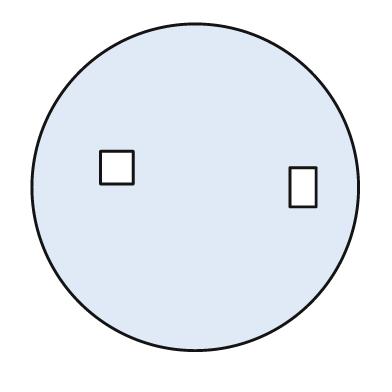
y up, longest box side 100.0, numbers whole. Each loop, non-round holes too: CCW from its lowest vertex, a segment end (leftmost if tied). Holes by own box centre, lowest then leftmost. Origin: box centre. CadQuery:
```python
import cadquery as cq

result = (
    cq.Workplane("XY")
    .moveTo(0.0, 0.0)
    .circle(50.0)
    .moveTo(29.0, -6.0)
    .lineTo(37.0, -6.0)
    .lineTo(37.0, 6.0)
    .lineTo(29.0, 6.0)
    .close()
    .moveTo(-29.0, 1.0)
    .lineTo(-19.0, 1.0)
    .lineTo(-19.0, 11.0)
    .lineTo(-29.0, 11.0)
    .close()
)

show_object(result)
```